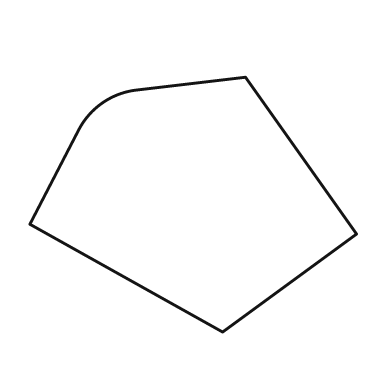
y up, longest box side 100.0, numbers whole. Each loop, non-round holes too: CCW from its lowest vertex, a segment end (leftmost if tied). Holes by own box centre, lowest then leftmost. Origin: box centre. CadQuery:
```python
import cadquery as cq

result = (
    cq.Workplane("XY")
    .moveTo(9.0, -39.0)
    .lineTo(50.0, -9.0)
    .lineTo(16.0, 39.0)
    .lineTo(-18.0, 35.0)
    .threePointArc((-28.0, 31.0), (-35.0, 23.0))
    .lineTo(-50.0, -6.0)
    .close()
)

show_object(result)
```